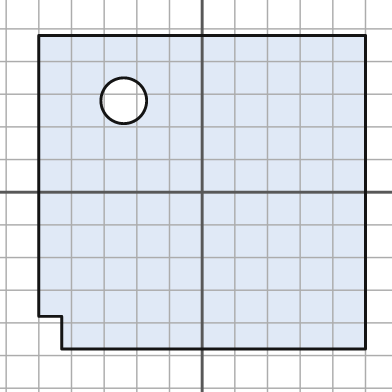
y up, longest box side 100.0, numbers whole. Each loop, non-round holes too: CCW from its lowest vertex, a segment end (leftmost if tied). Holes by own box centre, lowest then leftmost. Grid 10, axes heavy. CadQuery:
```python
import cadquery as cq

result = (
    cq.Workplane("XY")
    .moveTo(-43.0, -48.0)
    .lineTo(50.0, -48.0)
    .lineTo(50.0, 48.0)
    .lineTo(-50.0, 48.0)
    .lineTo(-50.0, -38.0)
    .lineTo(-43.0, -38.0)
    .close()
    .moveTo(-24.0, 28.0)
    .circle(7.0)
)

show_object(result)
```